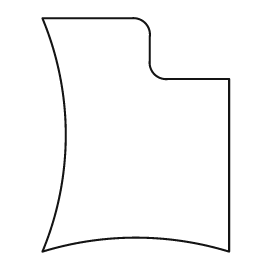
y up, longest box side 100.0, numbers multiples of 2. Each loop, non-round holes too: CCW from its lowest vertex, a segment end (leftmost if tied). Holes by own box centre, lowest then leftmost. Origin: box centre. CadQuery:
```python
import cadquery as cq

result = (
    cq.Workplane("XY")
    .moveTo(-40.0, -50.0)
    .threePointArc((0.0, -44.0), (40.0, -50.0))
    .lineTo(40.0, 24.0)
    .lineTo(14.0, 24.0)
    .threePointArc((8.0, 26.0), (6.0, 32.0))
    .lineTo(6.0, 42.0)
    .threePointArc((4.0, 48.0), (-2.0, 50.0))
    .lineTo(-40.0, 50.0)
    .threePointArc((-30.0, 0.0), (-40.0, -50.0))
    .close()
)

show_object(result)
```